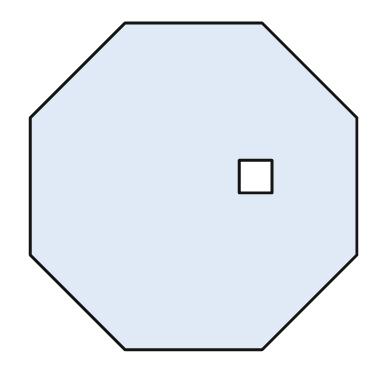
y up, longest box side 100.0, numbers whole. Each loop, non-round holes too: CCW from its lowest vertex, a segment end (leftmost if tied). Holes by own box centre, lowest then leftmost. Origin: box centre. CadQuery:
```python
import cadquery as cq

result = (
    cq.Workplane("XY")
    .moveTo(-21.0, -50.0)
    .lineTo(21.0, -50.0)
    .lineTo(50.0, -21.0)
    .lineTo(50.0, 21.0)
    .lineTo(21.0, 50.0)
    .lineTo(-21.0, 50.0)
    .lineTo(-50.0, 21.0)
    .lineTo(-50.0, -21.0)
    .close()
    .moveTo(14.0, -2.0)
    .lineTo(24.0, -2.0)
    .lineTo(24.0, 8.0)
    .lineTo(14.0, 8.0)
    .close()
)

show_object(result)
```